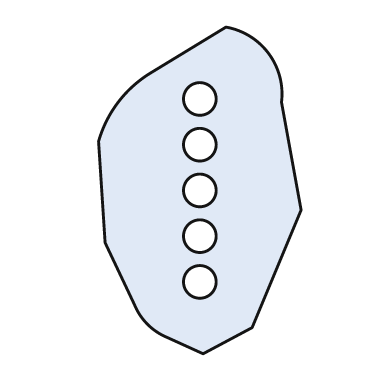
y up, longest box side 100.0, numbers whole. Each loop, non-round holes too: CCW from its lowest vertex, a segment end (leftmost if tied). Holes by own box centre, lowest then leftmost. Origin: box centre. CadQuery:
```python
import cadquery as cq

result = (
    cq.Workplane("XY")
    .moveTo(1.0, -50.0)
    .lineTo(16.0, -42.0)
    .lineTo(31.0, -6.0)
    .lineTo(25.0, 27.0)
    .threePointArc((21.0, 42.0), (8.0, 50.0))
    .lineTo(-15.0, 36.0)
    .threePointArc((-25.0, 27.0), (-31.0, 15.0))
    .lineTo(-29.0, -16.0)
    .lineTo(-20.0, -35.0)
    .threePointArc((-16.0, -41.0), (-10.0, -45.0))
    .close()
    .moveTo(0.0, -28.0)
    .circle(5.0)
    .moveTo(0.0, -14.0)
    .circle(5.0)
    .moveTo(0.0, 0.0)
    .circle(5.0)
    .moveTo(0.0, 14.0)
    .circle(5.0)
    .moveTo(0.0, 28.0)
    .circle(5.0)
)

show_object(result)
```